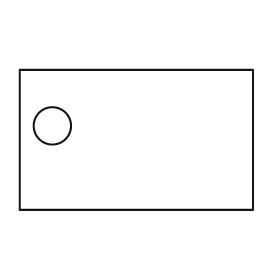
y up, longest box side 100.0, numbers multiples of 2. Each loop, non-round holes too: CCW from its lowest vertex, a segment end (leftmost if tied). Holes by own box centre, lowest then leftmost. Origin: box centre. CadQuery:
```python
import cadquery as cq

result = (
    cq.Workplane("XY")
    .moveTo(-50.0, -30.0)
    .lineTo(50.0, -30.0)
    .lineTo(50.0, 30.0)
    .lineTo(-50.0, 30.0)
    .close()
    .moveTo(-36.0, 6.0)
    .circle(8.0)
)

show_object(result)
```